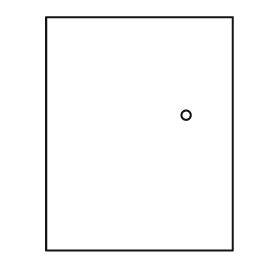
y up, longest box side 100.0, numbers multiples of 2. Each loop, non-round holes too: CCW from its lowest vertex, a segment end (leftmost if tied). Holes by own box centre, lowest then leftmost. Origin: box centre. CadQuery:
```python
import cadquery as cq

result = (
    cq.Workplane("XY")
    .moveTo(-40.0, -50.0)
    .lineTo(40.0, -50.0)
    .lineTo(40.0, 50.0)
    .lineTo(-40.0, 50.0)
    .close()
    .moveTo(20.0, 8.0)
    .circle(2.0)
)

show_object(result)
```